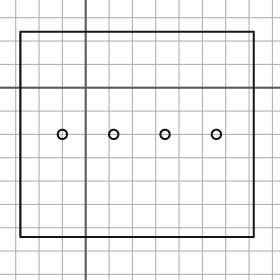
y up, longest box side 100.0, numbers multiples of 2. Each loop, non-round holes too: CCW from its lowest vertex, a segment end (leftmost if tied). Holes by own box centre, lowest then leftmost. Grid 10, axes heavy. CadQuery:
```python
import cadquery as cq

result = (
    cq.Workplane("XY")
    .moveTo(-28.0, -64.0)
    .lineTo(72.0, -64.0)
    .lineTo(72.0, 24.0)
    .lineTo(-28.0, 24.0)
    .close()
    .moveTo(-10.0, -20.0)
    .circle(2.0)
    .moveTo(12.0, -20.0)
    .circle(2.0)
    .moveTo(34.0, -20.0)
    .circle(2.0)
    .moveTo(56.0, -20.0)
    .circle(2.0)
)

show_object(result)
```